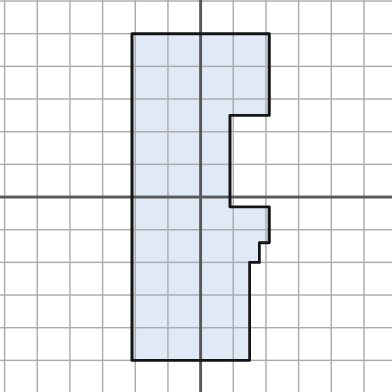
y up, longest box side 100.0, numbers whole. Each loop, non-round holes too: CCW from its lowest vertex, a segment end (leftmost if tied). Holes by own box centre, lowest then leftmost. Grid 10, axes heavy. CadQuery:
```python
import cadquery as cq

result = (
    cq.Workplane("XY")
    .moveTo(-21.0, -50.0)
    .lineTo(15.0, -50.0)
    .lineTo(15.0, -20.0)
    .lineTo(18.0, -20.0)
    .lineTo(18.0, -14.0)
    .lineTo(21.0, -14.0)
    .lineTo(21.0, -3.0)
    .lineTo(9.0, -3.0)
    .lineTo(9.0, 25.0)
    .lineTo(21.0, 25.0)
    .lineTo(21.0, 50.0)
    .lineTo(-21.0, 50.0)
    .close()
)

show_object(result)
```